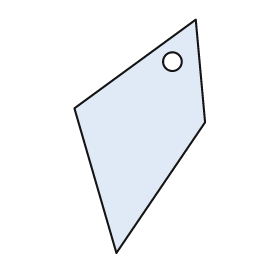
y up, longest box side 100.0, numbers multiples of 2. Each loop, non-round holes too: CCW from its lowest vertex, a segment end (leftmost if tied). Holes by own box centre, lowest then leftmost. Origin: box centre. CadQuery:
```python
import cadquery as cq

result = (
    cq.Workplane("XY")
    .moveTo(-10.0, -50.0)
    .lineTo(28.0, 6.0)
    .lineTo(24.0, 50.0)
    .lineTo(-28.0, 12.0)
    .close()
    .moveTo(14.0, 32.0)
    .circle(4.0)
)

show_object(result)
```